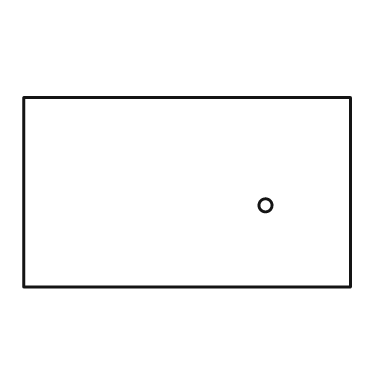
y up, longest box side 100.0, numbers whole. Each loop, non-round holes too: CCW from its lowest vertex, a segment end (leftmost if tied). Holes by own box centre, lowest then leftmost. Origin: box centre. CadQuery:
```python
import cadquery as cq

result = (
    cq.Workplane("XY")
    .moveTo(-50.0, -29.0)
    .lineTo(50.0, -29.0)
    .lineTo(50.0, 29.0)
    .lineTo(-50.0, 29.0)
    .close()
    .moveTo(24.0, -4.0)
    .circle(2.0)
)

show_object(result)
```